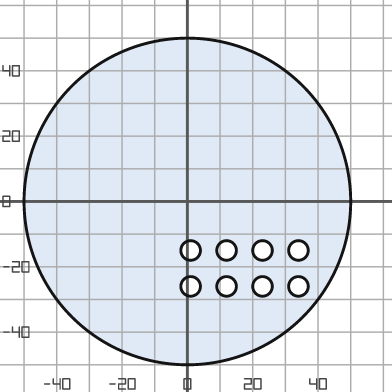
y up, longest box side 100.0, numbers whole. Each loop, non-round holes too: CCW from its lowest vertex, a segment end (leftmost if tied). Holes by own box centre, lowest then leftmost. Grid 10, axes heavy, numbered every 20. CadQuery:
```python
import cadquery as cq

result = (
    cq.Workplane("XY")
    .moveTo(0.0, 0.0)
    .circle(50.0)
    .moveTo(1.0, -26.0)
    .circle(3.0)
    .moveTo(12.0, -26.0)
    .circle(3.0)
    .moveTo(23.0, -26.0)
    .circle(3.0)
    .moveTo(34.0, -26.0)
    .circle(3.0)
    .moveTo(1.0, -15.0)
    .circle(3.0)
    .moveTo(12.0, -15.0)
    .circle(3.0)
    .moveTo(23.0, -15.0)
    .circle(3.0)
    .moveTo(34.0, -15.0)
    .circle(3.0)
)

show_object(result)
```